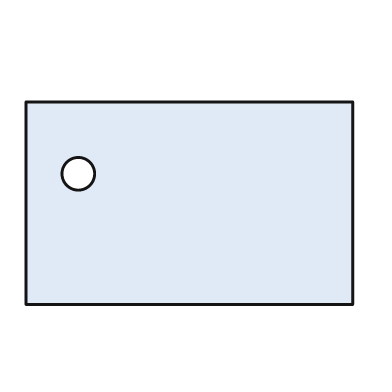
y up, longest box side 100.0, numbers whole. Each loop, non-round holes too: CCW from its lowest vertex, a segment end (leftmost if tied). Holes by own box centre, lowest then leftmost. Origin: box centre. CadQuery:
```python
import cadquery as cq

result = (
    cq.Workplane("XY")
    .moveTo(-50.0, -31.0)
    .lineTo(50.0, -31.0)
    .lineTo(50.0, 31.0)
    .lineTo(-50.0, 31.0)
    .close()
    .moveTo(-34.0, 9.0)
    .circle(5.0)
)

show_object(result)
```